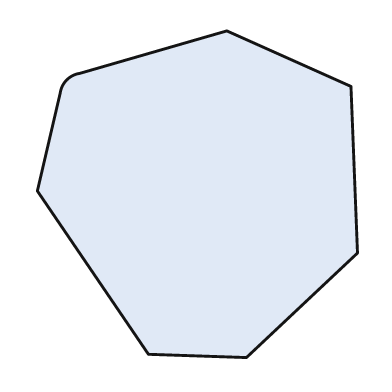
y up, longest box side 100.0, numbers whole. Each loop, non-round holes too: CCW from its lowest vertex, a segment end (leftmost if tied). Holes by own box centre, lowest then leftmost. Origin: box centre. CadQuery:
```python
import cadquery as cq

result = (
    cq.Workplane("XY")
    .moveTo(15.0, -50.0)
    .lineTo(49.0, -18.0)
    .lineTo(47.0, 33.0)
    .lineTo(9.0, 50.0)
    .lineTo(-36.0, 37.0)
    .threePointArc((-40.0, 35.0), (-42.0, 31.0))
    .lineTo(-49.0, 1.0)
    .lineTo(-15.0, -49.0)
    .close()
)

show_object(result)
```